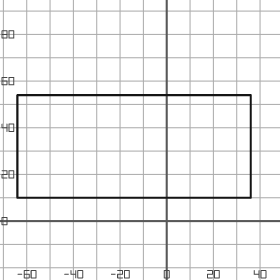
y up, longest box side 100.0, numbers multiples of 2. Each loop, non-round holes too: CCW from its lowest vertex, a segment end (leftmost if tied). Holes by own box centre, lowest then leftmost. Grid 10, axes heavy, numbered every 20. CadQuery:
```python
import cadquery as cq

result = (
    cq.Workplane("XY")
    .moveTo(-64.0, 10.0)
    .lineTo(36.0, 10.0)
    .lineTo(36.0, 54.0)
    .lineTo(-64.0, 54.0)
    .close()
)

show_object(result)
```